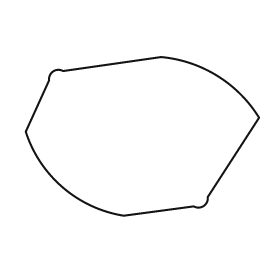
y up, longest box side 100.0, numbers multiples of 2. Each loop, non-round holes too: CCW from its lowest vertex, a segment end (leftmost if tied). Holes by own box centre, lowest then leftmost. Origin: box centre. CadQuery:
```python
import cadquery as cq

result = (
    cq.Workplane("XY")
    .moveTo(-8.0, -34.0)
    .lineTo(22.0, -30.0)
    .threePointArc((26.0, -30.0), (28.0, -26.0))
    .lineTo(50.0, 8.0)
    .threePointArc((32.0, 26.0), (8.0, 34.0))
    .lineTo(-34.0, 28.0)
    .threePointArc((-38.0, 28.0), (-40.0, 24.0))
    .lineTo(-50.0, 2.0)
    .threePointArc((-34.0, -22.0), (-8.0, -34.0))
    .close()
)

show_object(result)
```